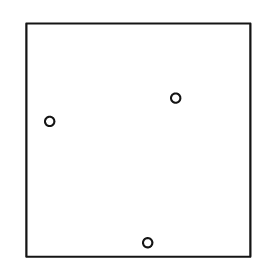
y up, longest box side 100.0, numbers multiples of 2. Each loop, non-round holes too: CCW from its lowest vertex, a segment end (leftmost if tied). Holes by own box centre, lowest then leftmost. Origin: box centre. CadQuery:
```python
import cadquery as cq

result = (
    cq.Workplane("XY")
    .moveTo(-48.0, -50.0)
    .lineTo(48.0, -50.0)
    .lineTo(48.0, 50.0)
    .lineTo(-48.0, 50.0)
    .close()
    .moveTo(4.0, -44.0)
    .circle(2.0)
    .moveTo(-38.0, 8.0)
    .circle(2.0)
    .moveTo(16.0, 18.0)
    .circle(2.0)
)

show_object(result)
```